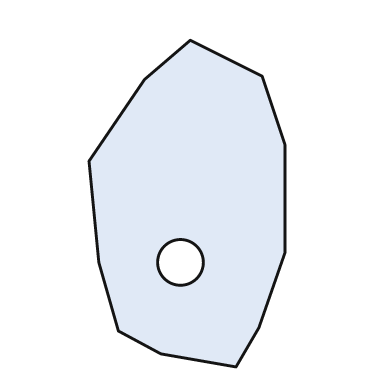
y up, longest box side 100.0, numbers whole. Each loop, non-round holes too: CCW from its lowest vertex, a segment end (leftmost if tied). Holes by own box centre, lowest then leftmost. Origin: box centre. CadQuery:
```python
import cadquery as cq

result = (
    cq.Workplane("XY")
    .moveTo(15.0, -50.0)
    .lineTo(22.0, -38.0)
    .lineTo(30.0, -15.0)
    .lineTo(30.0, 18.0)
    .lineTo(23.0, 39.0)
    .lineTo(1.0, 50.0)
    .lineTo(-13.0, 38.0)
    .lineTo(-30.0, 13.0)
    .lineTo(-27.0, -18.0)
    .lineTo(-21.0, -39.0)
    .lineTo(-8.0, -46.0)
    .close()
    .moveTo(-2.0, -18.0)
    .circle(7.0)
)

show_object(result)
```